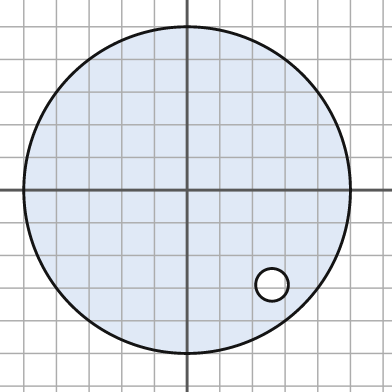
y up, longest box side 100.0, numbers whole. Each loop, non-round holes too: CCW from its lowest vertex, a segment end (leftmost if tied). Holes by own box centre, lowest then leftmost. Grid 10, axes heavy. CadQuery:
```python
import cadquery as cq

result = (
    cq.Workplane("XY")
    .moveTo(0.0, 0.0)
    .circle(50.0)
    .moveTo(26.0, -29.0)
    .circle(5.0)
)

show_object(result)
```